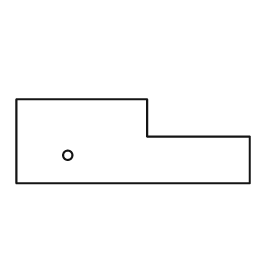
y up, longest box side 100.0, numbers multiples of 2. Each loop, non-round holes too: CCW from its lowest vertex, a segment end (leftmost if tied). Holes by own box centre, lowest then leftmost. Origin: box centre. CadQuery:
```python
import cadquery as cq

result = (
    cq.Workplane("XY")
    .moveTo(-50.0, -18.0)
    .lineTo(50.0, -18.0)
    .lineTo(50.0, 2.0)
    .lineTo(6.0, 2.0)
    .lineTo(6.0, 18.0)
    .lineTo(-50.0, 18.0)
    .close()
    .moveTo(-28.0, -6.0)
    .circle(2.0)
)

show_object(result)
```